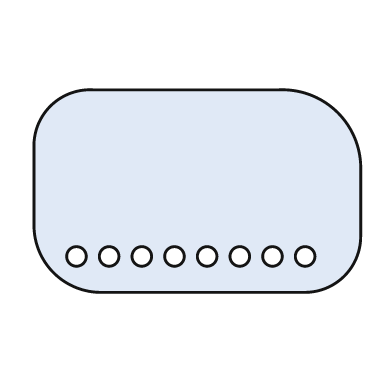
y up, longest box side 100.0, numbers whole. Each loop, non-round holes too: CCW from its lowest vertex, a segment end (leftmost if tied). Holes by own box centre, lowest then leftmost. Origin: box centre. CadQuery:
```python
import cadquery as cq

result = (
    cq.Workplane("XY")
    .moveTo(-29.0, -31.0)
    .lineTo(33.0, -31.0)
    .threePointArc((45.0, -26.0), (50.0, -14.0))
    .lineTo(50.0, 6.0)
    .threePointArc((43.0, 24.0), (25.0, 31.0))
    .lineTo(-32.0, 31.0)
    .threePointArc((-45.0, 26.0), (-50.0, 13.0))
    .lineTo(-50.0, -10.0)
    .threePointArc((-44.0, -25.0), (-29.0, -31.0))
    .close()
    .moveTo(-37.0, -20.0)
    .circle(3.0)
    .moveTo(-27.0, -20.0)
    .circle(3.0)
    .moveTo(-17.0, -20.0)
    .circle(3.0)
    .moveTo(-7.0, -20.0)
    .circle(3.0)
    .moveTo(3.0, -20.0)
    .circle(3.0)
    .moveTo(13.0, -20.0)
    .circle(3.0)
    .moveTo(23.0, -20.0)
    .circle(3.0)
    .moveTo(33.0, -20.0)
    .circle(3.0)
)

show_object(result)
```